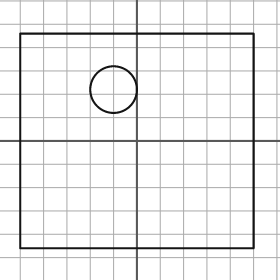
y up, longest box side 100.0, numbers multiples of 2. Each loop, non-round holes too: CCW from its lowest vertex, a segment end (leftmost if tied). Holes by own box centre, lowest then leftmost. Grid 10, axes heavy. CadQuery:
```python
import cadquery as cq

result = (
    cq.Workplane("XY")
    .moveTo(-50.0, -46.0)
    .lineTo(50.0, -46.0)
    .lineTo(50.0, 46.0)
    .lineTo(-50.0, 46.0)
    .close()
    .moveTo(-10.0, 22.0)
    .circle(10.0)
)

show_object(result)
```